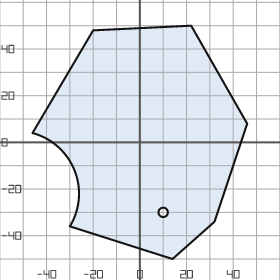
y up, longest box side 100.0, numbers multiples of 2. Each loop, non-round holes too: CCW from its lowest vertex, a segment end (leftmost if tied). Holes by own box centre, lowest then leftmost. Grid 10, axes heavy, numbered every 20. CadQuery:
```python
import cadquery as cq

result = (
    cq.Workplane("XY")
    .moveTo(14.0, -50.0)
    .lineTo(32.0, -34.0)
    .lineTo(46.0, 8.0)
    .lineTo(22.0, 50.0)
    .lineTo(-20.0, 48.0)
    .lineTo(-46.0, 4.0)
    .threePointArc((-28.0, -12.0), (-30.0, -36.0))
    .close()
    .moveTo(10.0, -30.0)
    .circle(2.0)
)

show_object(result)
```